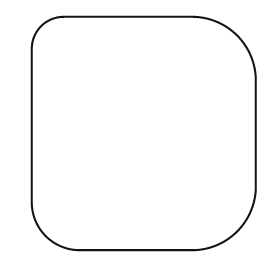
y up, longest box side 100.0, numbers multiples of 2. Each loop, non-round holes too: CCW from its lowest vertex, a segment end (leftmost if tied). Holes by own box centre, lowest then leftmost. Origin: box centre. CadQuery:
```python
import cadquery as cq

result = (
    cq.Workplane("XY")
    .moveTo(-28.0, -50.0)
    .lineTo(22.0, -50.0)
    .threePointArc((40.0, -42.0), (48.0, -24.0))
    .lineTo(48.0, 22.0)
    .threePointArc((40.0, 42.0), (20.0, 50.0))
    .lineTo(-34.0, 50.0)
    .threePointArc((-44.0, 46.0), (-48.0, 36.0))
    .lineTo(-48.0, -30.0)
    .threePointArc((-42.0, -44.0), (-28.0, -50.0))
    .close()
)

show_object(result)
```